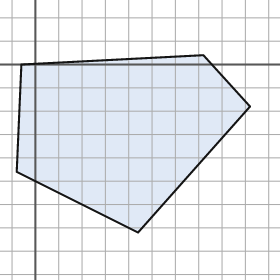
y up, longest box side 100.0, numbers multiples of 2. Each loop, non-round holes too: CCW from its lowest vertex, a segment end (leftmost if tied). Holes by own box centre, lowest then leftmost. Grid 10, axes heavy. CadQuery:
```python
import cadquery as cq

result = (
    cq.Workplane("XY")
    .moveTo(44.0, -72.0)
    .lineTo(92.0, -18.0)
    .lineTo(72.0, 4.0)
    .lineTo(-6.0, 0.0)
    .lineTo(-8.0, -46.0)
    .close()
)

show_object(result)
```